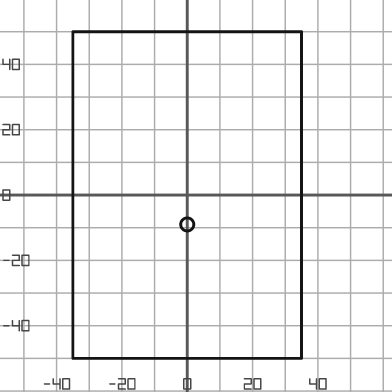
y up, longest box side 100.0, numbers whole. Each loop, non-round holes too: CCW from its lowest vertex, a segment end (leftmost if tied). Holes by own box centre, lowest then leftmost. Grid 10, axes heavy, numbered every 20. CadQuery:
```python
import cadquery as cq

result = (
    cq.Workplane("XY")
    .moveTo(-35.0, -50.0)
    .lineTo(35.0, -50.0)
    .lineTo(35.0, 50.0)
    .lineTo(-35.0, 50.0)
    .close()
    .moveTo(0.0, -9.0)
    .circle(2.0)
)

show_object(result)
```